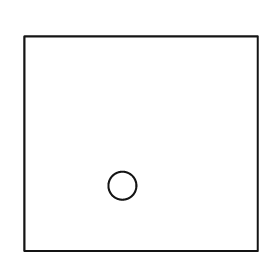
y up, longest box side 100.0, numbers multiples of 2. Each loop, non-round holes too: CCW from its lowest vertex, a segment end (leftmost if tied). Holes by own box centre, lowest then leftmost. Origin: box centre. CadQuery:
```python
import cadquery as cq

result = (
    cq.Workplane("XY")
    .moveTo(-50.0, -46.0)
    .lineTo(50.0, -46.0)
    .lineTo(50.0, 46.0)
    .lineTo(-50.0, 46.0)
    .close()
    .moveTo(-8.0, -18.0)
    .circle(6.0)
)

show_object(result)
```